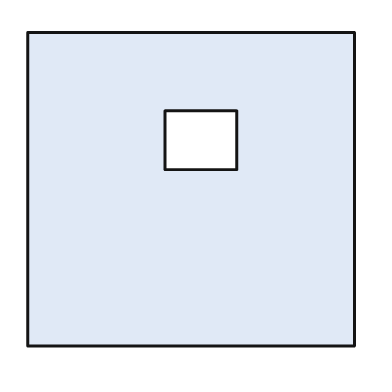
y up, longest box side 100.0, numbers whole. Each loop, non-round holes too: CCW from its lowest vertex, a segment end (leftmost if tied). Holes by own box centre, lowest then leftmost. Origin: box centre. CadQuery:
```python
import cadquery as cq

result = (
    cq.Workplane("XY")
    .moveTo(-50.0, -48.0)
    .lineTo(50.0, -48.0)
    .lineTo(50.0, 48.0)
    .lineTo(-50.0, 48.0)
    .close()
    .moveTo(-8.0, 6.0)
    .lineTo(14.0, 6.0)
    .lineTo(14.0, 24.0)
    .lineTo(-8.0, 24.0)
    .close()
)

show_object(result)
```